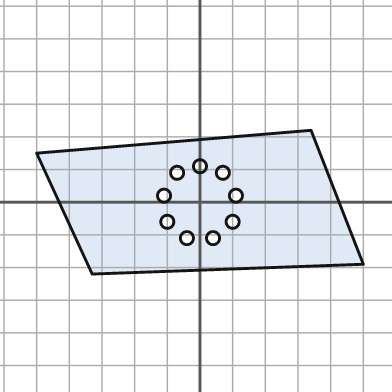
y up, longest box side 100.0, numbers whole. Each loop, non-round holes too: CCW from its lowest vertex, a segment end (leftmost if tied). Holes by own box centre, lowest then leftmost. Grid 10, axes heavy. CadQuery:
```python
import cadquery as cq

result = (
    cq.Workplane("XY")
    .moveTo(-33.0, -22.0)
    .lineTo(50.0, -19.0)
    .lineTo(34.0, 22.0)
    .lineTo(-50.0, 15.0)
    .close()
    .moveTo(-4.0, -11.0)
    .circle(2.0)
    .moveTo(4.0, -11.0)
    .circle(2.0)
    .moveTo(-10.0, -6.0)
    .circle(2.0)
    .moveTo(10.0, -6.0)
    .circle(2.0)
    .moveTo(-11.0, 2.0)
    .circle(2.0)
    .moveTo(11.0, 2.0)
    .circle(2.0)
    .moveTo(-7.0, 9.0)
    .circle(2.0)
    .moveTo(7.0, 9.0)
    .circle(2.0)
    .moveTo(0.0, 11.0)
    .circle(2.0)
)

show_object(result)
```